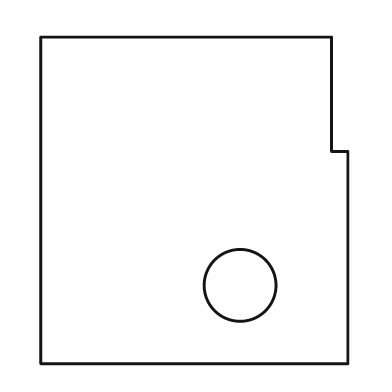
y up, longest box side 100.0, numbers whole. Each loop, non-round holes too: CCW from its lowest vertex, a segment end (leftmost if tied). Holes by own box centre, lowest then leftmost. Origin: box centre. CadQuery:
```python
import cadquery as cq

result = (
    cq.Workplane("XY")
    .moveTo(-47.0, -50.0)
    .lineTo(47.0, -50.0)
    .lineTo(47.0, 15.0)
    .lineTo(42.0, 15.0)
    .lineTo(42.0, 50.0)
    .lineTo(-47.0, 50.0)
    .close()
    .moveTo(14.0, -26.0)
    .circle(11.0)
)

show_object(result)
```